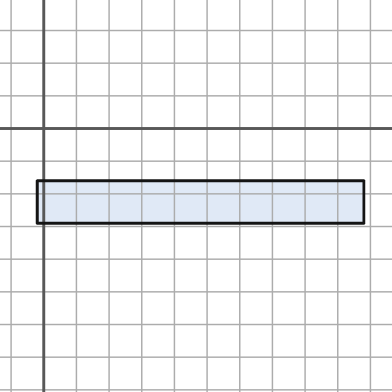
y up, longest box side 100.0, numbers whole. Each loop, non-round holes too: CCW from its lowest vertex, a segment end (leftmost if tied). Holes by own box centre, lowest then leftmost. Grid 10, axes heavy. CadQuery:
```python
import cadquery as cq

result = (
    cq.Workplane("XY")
    .moveTo(-2.0, -29.0)
    .lineTo(98.0, -29.0)
    .lineTo(98.0, -16.0)
    .lineTo(-2.0, -16.0)
    .close()
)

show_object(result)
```